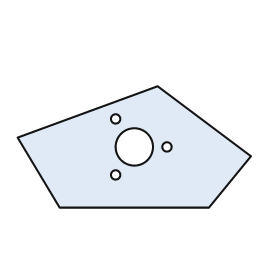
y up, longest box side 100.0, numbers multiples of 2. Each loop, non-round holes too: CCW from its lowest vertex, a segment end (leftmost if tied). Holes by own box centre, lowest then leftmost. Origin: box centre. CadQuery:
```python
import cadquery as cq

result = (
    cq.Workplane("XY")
    .moveTo(-32.0, -26.0)
    .lineTo(32.0, -26.0)
    .lineTo(50.0, -4.0)
    .lineTo(10.0, 26.0)
    .lineTo(-50.0, 4.0)
    .close()
    .moveTo(-8.0, -12.0)
    .circle(2.0)
    .moveTo(0.0, 0.0)
    .circle(8.0)
    .moveTo(14.0, 0.0)
    .circle(2.0)
    .moveTo(-8.0, 12.0)
    .circle(2.0)
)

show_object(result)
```